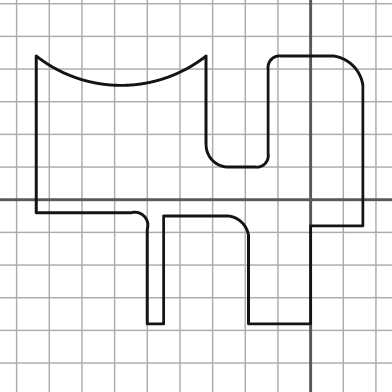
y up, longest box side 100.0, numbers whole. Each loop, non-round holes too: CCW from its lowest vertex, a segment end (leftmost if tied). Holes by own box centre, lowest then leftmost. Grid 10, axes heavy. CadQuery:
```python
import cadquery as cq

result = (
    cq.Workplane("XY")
    .moveTo(-50.0, -38.0)
    .lineTo(-45.0, -38.0)
    .lineTo(-45.0, -5.0)
    .lineTo(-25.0, -5.0)
    .threePointArc((-21.0, -7.0), (-19.0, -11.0))
    .lineTo(-19.0, -38.0)
    .lineTo(0.0, -38.0)
    .lineTo(0.0, -8.0)
    .lineTo(16.0, -8.0)
    .lineTo(16.0, 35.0)
    .threePointArc((13.0, 41.0), (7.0, 44.0))
    .lineTo(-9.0, 44.0)
    .threePointArc((-12.0, 43.0), (-13.0, 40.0))
    .lineTo(-13.0, 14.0)
    .threePointArc((-14.0, 11.0), (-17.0, 10.0))
    .lineTo(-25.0, 10.0)
    .threePointArc((-30.0, 12.0), (-32.0, 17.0))
    .lineTo(-32.0, 44.0)
    .threePointArc((-58.0, 35.0), (-84.0, 44.0))
    .lineTo(-84.0, -4.0)
    .lineTo(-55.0, -4.0)
    .threePointArc((-51.0, -5.0), (-50.0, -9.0))
    .close()
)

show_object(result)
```